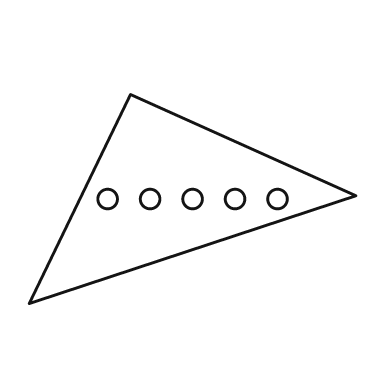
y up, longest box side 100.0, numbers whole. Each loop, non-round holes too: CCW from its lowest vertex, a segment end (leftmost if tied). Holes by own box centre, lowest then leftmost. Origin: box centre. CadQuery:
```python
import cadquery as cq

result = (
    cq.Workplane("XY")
    .moveTo(-50.0, -32.0)
    .lineTo(50.0, 1.0)
    .lineTo(-19.0, 32.0)
    .close()
    .moveTo(-26.0, 0.0)
    .circle(3.0)
    .moveTo(-13.0, 0.0)
    .circle(3.0)
    .moveTo(0.0, 0.0)
    .circle(3.0)
    .moveTo(13.0, 0.0)
    .circle(3.0)
    .moveTo(26.0, 0.0)
    .circle(3.0)
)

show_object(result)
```